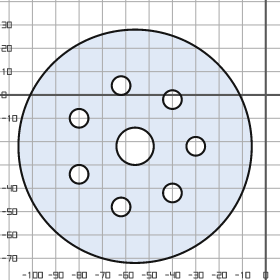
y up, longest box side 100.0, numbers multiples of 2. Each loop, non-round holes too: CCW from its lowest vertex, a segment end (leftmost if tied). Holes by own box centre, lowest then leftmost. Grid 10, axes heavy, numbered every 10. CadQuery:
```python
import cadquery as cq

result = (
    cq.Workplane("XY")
    .moveTo(-56.0, -22.0)
    .circle(50.0)
    .moveTo(-62.0, -48.0)
    .circle(4.0)
    .moveTo(-40.0, -42.0)
    .circle(4.0)
    .moveTo(-80.0, -34.0)
    .circle(4.0)
    .moveTo(-56.0, -22.0)
    .circle(8.0)
    .moveTo(-30.0, -22.0)
    .circle(4.0)
    .moveTo(-80.0, -10.0)
    .circle(4.0)
    .moveTo(-40.0, -2.0)
    .circle(4.0)
    .moveTo(-62.0, 4.0)
    .circle(4.0)
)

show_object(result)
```